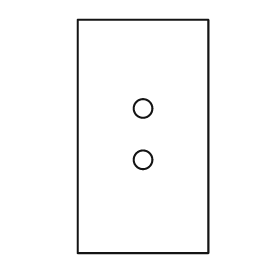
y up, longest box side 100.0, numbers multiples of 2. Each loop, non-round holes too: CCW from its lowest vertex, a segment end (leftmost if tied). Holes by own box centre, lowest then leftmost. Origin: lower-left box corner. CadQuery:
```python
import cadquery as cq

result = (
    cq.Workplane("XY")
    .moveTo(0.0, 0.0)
    .lineTo(56.0, 0.0)
    .lineTo(56.0, 100.0)
    .lineTo(0.0, 100.0)
    .close()
    .moveTo(28.0, 40.0)
    .circle(4.0)
    .moveTo(28.0, 62.0)
    .circle(4.0)
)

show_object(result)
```